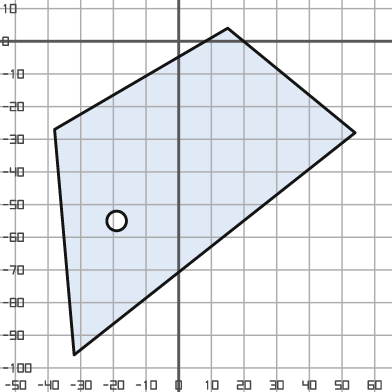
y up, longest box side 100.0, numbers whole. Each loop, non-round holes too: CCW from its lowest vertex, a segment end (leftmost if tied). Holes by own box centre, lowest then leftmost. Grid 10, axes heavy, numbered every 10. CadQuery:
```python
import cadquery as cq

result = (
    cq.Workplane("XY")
    .moveTo(-32.0, -96.0)
    .lineTo(54.0, -28.0)
    .lineTo(15.0, 4.0)
    .lineTo(-38.0, -27.0)
    .close()
    .moveTo(-19.0, -55.0)
    .circle(3.0)
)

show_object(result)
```